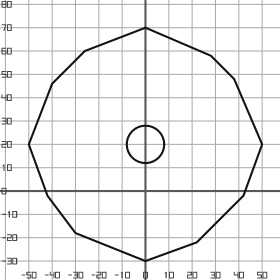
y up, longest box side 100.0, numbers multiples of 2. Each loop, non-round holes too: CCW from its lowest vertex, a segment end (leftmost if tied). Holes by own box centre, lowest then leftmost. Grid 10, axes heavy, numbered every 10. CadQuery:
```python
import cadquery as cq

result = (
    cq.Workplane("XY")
    .moveTo(0.0, -30.0)
    .lineTo(22.0, -22.0)
    .lineTo(42.0, -2.0)
    .lineTo(50.0, 20.0)
    .lineTo(38.0, 48.0)
    .lineTo(28.0, 58.0)
    .lineTo(0.0, 70.0)
    .lineTo(-26.0, 60.0)
    .lineTo(-40.0, 46.0)
    .lineTo(-50.0, 20.0)
    .lineTo(-42.0, -2.0)
    .lineTo(-30.0, -18.0)
    .close()
    .moveTo(0.0, 20.0)
    .circle(8.0)
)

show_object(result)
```